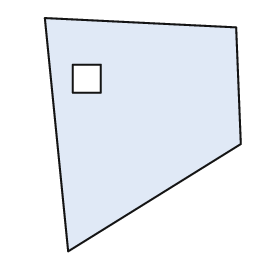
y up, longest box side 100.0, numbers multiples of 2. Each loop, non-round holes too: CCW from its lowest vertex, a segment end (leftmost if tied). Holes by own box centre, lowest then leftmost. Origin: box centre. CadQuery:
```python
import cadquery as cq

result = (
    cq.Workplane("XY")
    .moveTo(-32.0, -50.0)
    .lineTo(42.0, -4.0)
    .lineTo(40.0, 46.0)
    .lineTo(-42.0, 50.0)
    .close()
    .moveTo(-30.0, 18.0)
    .lineTo(-18.0, 18.0)
    .lineTo(-18.0, 30.0)
    .lineTo(-30.0, 30.0)
    .close()
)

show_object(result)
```